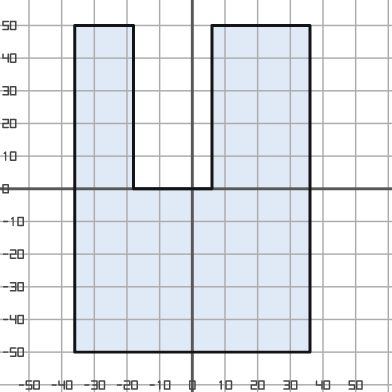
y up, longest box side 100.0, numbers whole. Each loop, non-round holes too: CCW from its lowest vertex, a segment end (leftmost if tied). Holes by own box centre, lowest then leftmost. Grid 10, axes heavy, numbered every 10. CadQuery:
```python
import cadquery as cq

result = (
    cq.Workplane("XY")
    .moveTo(-36.0, -50.0)
    .lineTo(36.0, -50.0)
    .lineTo(36.0, 50.0)
    .lineTo(6.0, 50.0)
    .lineTo(6.0, 0.0)
    .lineTo(-18.0, 0.0)
    .lineTo(-18.0, 50.0)
    .lineTo(-36.0, 50.0)
    .close()
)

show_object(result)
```